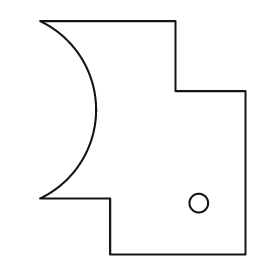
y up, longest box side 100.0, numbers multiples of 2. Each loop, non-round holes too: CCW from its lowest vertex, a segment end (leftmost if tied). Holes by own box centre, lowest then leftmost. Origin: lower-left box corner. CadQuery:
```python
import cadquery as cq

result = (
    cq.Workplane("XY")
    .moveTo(30.0, 0.0)
    .lineTo(88.0, 0.0)
    .lineTo(88.0, 70.0)
    .lineTo(58.0, 70.0)
    .lineTo(58.0, 100.0)
    .lineTo(0.0, 100.0)
    .threePointArc((24.0, 62.0), (0.0, 24.0))
    .lineTo(30.0, 24.0)
    .close()
    .moveTo(68.0, 22.0)
    .circle(4.0)
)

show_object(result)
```